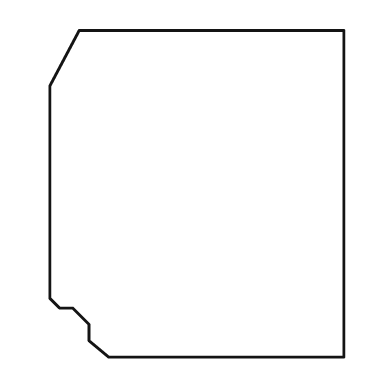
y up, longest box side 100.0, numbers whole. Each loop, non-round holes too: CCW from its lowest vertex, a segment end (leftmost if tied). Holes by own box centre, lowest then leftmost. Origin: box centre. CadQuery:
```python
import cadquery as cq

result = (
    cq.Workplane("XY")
    .moveTo(-27.0, -50.0)
    .lineTo(45.0, -50.0)
    .lineTo(45.0, 50.0)
    .lineTo(-36.0, 50.0)
    .lineTo(-45.0, 33.0)
    .lineTo(-45.0, -32.0)
    .lineTo(-42.0, -35.0)
    .lineTo(-38.0, -35.0)
    .lineTo(-33.0, -40.0)
    .lineTo(-33.0, -45.0)
    .close()
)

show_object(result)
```